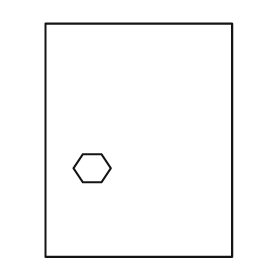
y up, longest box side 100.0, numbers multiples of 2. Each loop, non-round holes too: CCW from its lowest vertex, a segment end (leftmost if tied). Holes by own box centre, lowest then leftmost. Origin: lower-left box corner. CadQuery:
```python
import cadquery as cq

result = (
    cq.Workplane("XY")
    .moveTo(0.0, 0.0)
    .lineTo(80.0, 0.0)
    .lineTo(80.0, 100.0)
    .lineTo(0.0, 100.0)
    .close()
    .moveTo(16.0, 32.0)
    .lineTo(24.0, 32.0)
    .lineTo(28.0, 38.0)
    .lineTo(24.0, 44.0)
    .lineTo(16.0, 44.0)
    .lineTo(12.0, 38.0)
    .close()
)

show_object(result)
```